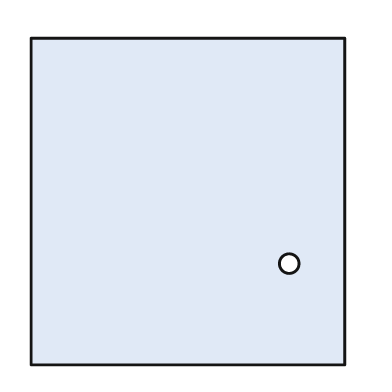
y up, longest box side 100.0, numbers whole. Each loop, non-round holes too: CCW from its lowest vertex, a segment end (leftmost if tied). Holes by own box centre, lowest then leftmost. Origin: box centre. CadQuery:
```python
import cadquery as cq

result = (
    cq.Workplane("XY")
    .moveTo(-48.0, -50.0)
    .lineTo(48.0, -50.0)
    .lineTo(48.0, 50.0)
    .lineTo(-48.0, 50.0)
    .close()
    .moveTo(31.0, -19.0)
    .circle(3.0)
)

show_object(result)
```